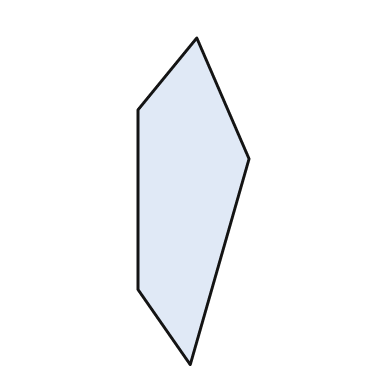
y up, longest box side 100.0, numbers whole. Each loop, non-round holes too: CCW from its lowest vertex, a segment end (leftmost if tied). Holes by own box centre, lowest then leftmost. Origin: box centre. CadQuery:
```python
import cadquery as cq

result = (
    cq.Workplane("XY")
    .moveTo(-1.0, -50.0)
    .lineTo(17.0, 13.0)
    .lineTo(1.0, 50.0)
    .lineTo(-17.0, 28.0)
    .lineTo(-17.0, -27.0)
    .close()
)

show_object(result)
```